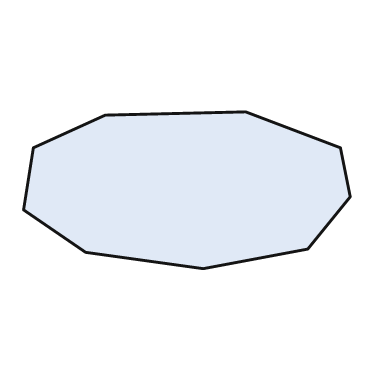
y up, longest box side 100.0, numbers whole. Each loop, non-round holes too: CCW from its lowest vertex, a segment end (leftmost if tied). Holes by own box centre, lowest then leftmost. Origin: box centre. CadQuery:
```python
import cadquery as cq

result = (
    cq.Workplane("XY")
    .moveTo(5.0, -24.0)
    .lineTo(37.0, -18.0)
    .lineTo(50.0, -2.0)
    .lineTo(47.0, 13.0)
    .lineTo(18.0, 24.0)
    .lineTo(-25.0, 23.0)
    .lineTo(-47.0, 13.0)
    .lineTo(-50.0, -6.0)
    .lineTo(-31.0, -19.0)
    .close()
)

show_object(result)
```